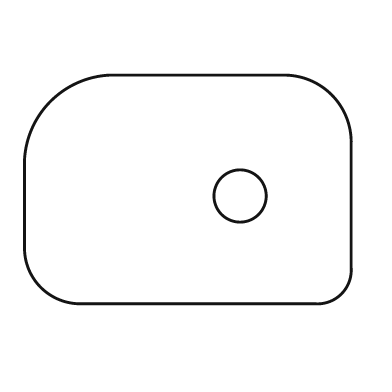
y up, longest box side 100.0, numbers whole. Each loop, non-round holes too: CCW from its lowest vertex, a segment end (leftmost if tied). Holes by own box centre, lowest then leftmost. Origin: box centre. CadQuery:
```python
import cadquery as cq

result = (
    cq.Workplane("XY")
    .moveTo(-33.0, -35.0)
    .lineTo(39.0, -35.0)
    .threePointArc((47.0, -32.0), (50.0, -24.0))
    .lineTo(50.0, 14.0)
    .threePointArc((44.0, 29.0), (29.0, 35.0))
    .lineTo(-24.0, 35.0)
    .threePointArc((-42.0, 27.0), (-50.0, 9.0))
    .lineTo(-50.0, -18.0)
    .threePointArc((-45.0, -30.0), (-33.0, -35.0))
    .close()
    .moveTo(16.0, -2.0)
    .circle(8.0)
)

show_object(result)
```